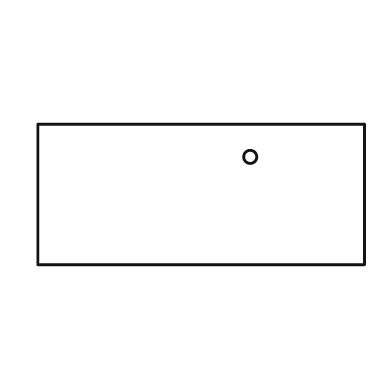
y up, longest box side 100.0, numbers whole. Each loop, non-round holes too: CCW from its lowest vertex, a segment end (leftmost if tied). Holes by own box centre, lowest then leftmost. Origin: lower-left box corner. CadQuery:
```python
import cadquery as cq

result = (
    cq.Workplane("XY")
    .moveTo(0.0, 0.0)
    .lineTo(100.0, 0.0)
    .lineTo(100.0, 43.0)
    .lineTo(0.0, 43.0)
    .close()
    .moveTo(65.0, 33.0)
    .circle(2.0)
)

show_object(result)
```